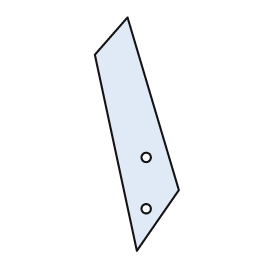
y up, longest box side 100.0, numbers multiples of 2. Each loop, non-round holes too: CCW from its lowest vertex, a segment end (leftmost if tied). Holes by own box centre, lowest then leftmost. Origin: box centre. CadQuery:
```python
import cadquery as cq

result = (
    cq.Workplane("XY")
    .moveTo(0.0, -50.0)
    .lineTo(18.0, -24.0)
    .lineTo(-4.0, 50.0)
    .lineTo(-18.0, 34.0)
    .close()
    .moveTo(4.0, -32.0)
    .circle(2.0)
    .moveTo(4.0, -10.0)
    .circle(2.0)
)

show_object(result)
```